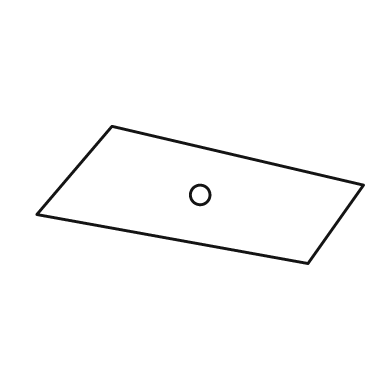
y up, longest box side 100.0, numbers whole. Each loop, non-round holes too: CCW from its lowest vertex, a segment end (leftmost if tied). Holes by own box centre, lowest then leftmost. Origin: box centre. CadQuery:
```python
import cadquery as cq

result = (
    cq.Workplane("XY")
    .moveTo(33.0, -21.0)
    .lineTo(50.0, 3.0)
    .lineTo(-27.0, 21.0)
    .lineTo(-50.0, -6.0)
    .close()
    .moveTo(0.0, 0.0)
    .circle(3.0)
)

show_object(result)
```